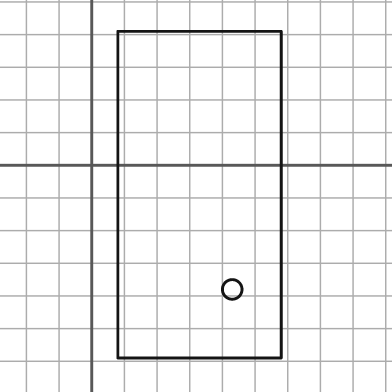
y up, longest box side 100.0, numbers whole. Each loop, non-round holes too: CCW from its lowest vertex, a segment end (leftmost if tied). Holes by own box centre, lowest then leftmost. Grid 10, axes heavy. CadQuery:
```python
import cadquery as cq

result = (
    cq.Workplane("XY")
    .moveTo(8.0, -59.0)
    .lineTo(58.0, -59.0)
    .lineTo(58.0, 41.0)
    .lineTo(8.0, 41.0)
    .close()
    .moveTo(43.0, -38.0)
    .circle(3.0)
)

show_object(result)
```